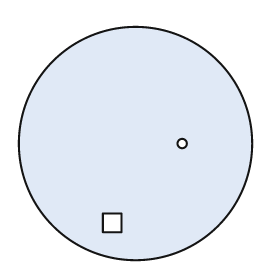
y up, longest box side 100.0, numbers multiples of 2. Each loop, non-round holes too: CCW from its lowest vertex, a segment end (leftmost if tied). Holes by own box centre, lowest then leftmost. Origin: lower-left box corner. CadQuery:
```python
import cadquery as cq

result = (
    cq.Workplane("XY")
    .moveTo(50.0, 50.0)
    .circle(50.0)
    .moveTo(36.0, 12.0)
    .lineTo(44.0, 12.0)
    .lineTo(44.0, 20.0)
    .lineTo(36.0, 20.0)
    .close()
    .moveTo(70.0, 50.0)
    .circle(2.0)
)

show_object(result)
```